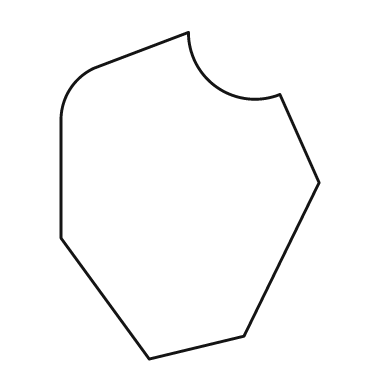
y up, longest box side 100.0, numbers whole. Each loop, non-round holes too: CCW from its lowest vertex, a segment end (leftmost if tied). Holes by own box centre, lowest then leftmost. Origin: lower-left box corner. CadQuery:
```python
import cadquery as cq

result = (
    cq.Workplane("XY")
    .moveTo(27.0, 0.0)
    .lineTo(56.0, 7.0)
    .lineTo(79.0, 54.0)
    .lineTo(67.0, 81.0)
    .threePointArc((48.0, 83.0), (39.0, 100.0))
    .lineTo(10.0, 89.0)
    .threePointArc((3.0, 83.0), (0.0, 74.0))
    .lineTo(0.0, 37.0)
    .close()
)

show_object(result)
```